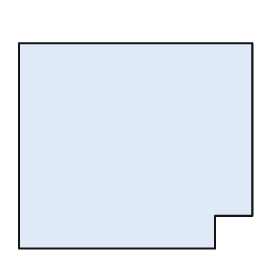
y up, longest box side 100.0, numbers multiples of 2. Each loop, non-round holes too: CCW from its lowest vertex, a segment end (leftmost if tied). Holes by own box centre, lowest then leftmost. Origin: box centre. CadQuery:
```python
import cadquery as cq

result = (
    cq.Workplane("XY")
    .moveTo(-50.0, -44.0)
    .lineTo(34.0, -44.0)
    .lineTo(34.0, -30.0)
    .lineTo(50.0, -30.0)
    .lineTo(50.0, 44.0)
    .lineTo(-50.0, 44.0)
    .close()
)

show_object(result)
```